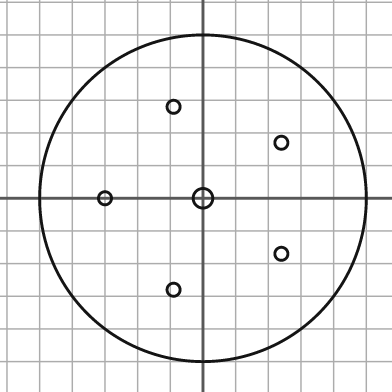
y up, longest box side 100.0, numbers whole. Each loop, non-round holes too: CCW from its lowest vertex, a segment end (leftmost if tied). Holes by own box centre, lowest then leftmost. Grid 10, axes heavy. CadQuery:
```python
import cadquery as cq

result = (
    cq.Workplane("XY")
    .moveTo(0.0, 0.0)
    .circle(50.0)
    .moveTo(-9.0, -28.0)
    .circle(2.0)
    .moveTo(24.0, -17.0)
    .circle(2.0)
    .moveTo(-30.0, 0.0)
    .circle(2.0)
    .moveTo(0.0, 0.0)
    .circle(3.0)
    .moveTo(24.0, 17.0)
    .circle(2.0)
    .moveTo(-9.0, 28.0)
    .circle(2.0)
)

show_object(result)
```